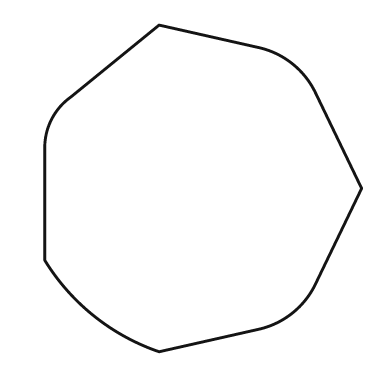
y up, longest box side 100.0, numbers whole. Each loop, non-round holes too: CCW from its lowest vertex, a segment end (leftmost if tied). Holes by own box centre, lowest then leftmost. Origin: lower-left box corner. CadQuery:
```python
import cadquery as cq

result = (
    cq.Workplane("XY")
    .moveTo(35.0, 0.0)
    .lineTo(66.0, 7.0)
    .threePointArc((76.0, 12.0), (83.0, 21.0))
    .lineTo(97.0, 50.0)
    .lineTo(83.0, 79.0)
    .threePointArc((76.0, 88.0), (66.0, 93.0))
    .lineTo(35.0, 100.0)
    .lineTo(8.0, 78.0)
    .threePointArc((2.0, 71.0), (0.0, 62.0))
    .lineTo(0.0, 28.0)
    .threePointArc((15.0, 11.0), (35.0, 0.0))
    .close()
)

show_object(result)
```